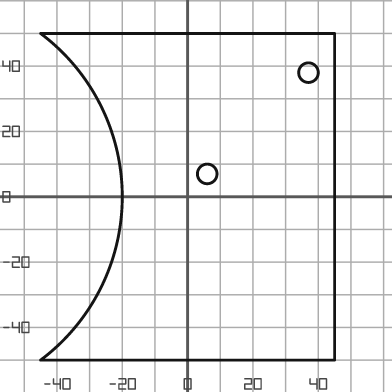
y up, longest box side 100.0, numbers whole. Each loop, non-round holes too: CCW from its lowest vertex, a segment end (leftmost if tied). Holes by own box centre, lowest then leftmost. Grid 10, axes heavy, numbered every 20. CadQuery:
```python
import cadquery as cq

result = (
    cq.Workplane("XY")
    .moveTo(-45.0, -50.0)
    .lineTo(45.0, -50.0)
    .lineTo(45.0, 50.0)
    .lineTo(-45.0, 50.0)
    .threePointArc((-20.0, 0.0), (-45.0, -50.0))
    .close()
    .moveTo(6.0, 7.0)
    .circle(3.0)
    .moveTo(37.0, 38.0)
    .circle(3.0)
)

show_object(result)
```